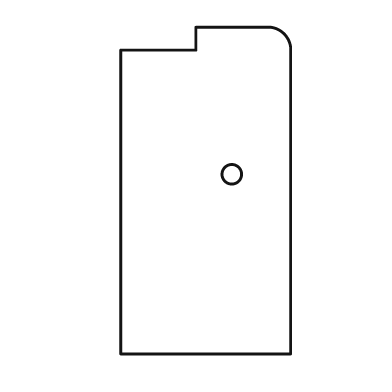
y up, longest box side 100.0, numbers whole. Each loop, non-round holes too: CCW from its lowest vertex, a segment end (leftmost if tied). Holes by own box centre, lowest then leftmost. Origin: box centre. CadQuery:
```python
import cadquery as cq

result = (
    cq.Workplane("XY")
    .moveTo(-26.0, -50.0)
    .lineTo(26.0, -50.0)
    .lineTo(26.0, 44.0)
    .threePointArc((24.0, 48.0), (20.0, 50.0))
    .lineTo(-3.0, 50.0)
    .lineTo(-3.0, 43.0)
    .lineTo(-26.0, 43.0)
    .close()
    .moveTo(8.0, 5.0)
    .circle(3.0)
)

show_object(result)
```